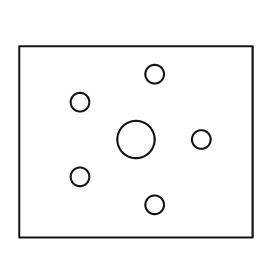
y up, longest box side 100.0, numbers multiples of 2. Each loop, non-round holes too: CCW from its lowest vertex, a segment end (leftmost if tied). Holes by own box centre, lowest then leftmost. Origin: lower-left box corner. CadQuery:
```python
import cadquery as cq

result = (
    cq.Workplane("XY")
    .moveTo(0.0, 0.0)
    .lineTo(100.0, 0.0)
    .lineTo(100.0, 82.0)
    .lineTo(0.0, 82.0)
    .close()
    .moveTo(58.0, 14.0)
    .circle(4.0)
    .moveTo(26.0, 26.0)
    .circle(4.0)
    .moveTo(50.0, 42.0)
    .circle(8.0)
    .moveTo(78.0, 42.0)
    .circle(4.0)
    .moveTo(26.0, 58.0)
    .circle(4.0)
    .moveTo(58.0, 70.0)
    .circle(4.0)
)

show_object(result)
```